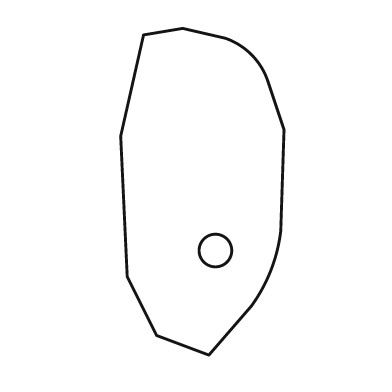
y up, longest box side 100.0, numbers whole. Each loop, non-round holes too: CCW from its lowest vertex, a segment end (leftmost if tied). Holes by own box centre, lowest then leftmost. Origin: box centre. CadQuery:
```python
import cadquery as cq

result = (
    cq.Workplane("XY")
    .moveTo(2.0, -50.0)
    .lineTo(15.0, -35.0)
    .threePointArc((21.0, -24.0), (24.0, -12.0))
    .lineTo(25.0, 19.0)
    .lineTo(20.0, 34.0)
    .threePointArc((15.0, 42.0), (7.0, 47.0))
    .lineTo(-6.0, 50.0)
    .lineTo(-18.0, 48.0)
    .lineTo(-25.0, 17.0)
    .lineTo(-23.0, -26.0)
    .lineTo(-14.0, -44.0)
    .close()
    .moveTo(4.0, -18.0)
    .circle(5.0)
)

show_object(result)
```